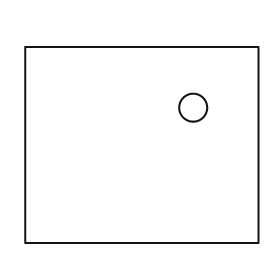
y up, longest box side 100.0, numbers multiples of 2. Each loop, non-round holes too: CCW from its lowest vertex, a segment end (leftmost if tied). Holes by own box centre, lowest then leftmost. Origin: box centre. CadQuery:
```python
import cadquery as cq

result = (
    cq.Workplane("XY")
    .moveTo(-50.0, -42.0)
    .lineTo(50.0, -42.0)
    .lineTo(50.0, 42.0)
    .lineTo(-50.0, 42.0)
    .close()
    .moveTo(22.0, 16.0)
    .circle(6.0)
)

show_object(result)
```